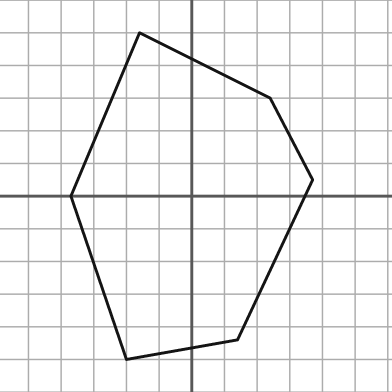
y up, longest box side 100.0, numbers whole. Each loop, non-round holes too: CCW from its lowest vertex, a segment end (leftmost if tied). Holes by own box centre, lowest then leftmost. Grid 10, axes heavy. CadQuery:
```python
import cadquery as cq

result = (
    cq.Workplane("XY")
    .moveTo(-20.0, -50.0)
    .lineTo(14.0, -44.0)
    .lineTo(37.0, 5.0)
    .lineTo(24.0, 30.0)
    .lineTo(-16.0, 50.0)
    .lineTo(-37.0, 0.0)
    .close()
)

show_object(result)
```